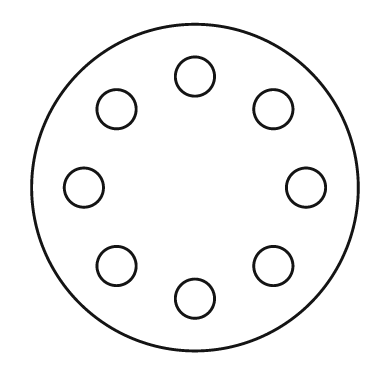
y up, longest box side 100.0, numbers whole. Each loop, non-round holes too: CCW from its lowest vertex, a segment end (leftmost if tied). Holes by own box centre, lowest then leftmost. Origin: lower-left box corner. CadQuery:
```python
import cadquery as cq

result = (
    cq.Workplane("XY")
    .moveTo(50.0, 50.0)
    .circle(50.0)
    .moveTo(50.0, 16.0)
    .circle(6.0)
    .moveTo(26.0, 26.0)
    .circle(6.0)
    .moveTo(74.0, 26.0)
    .circle(6.0)
    .moveTo(16.0, 50.0)
    .circle(6.0)
    .moveTo(84.0, 50.0)
    .circle(6.0)
    .moveTo(26.0, 74.0)
    .circle(6.0)
    .moveTo(74.0, 74.0)
    .circle(6.0)
    .moveTo(50.0, 84.0)
    .circle(6.0)
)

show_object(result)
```